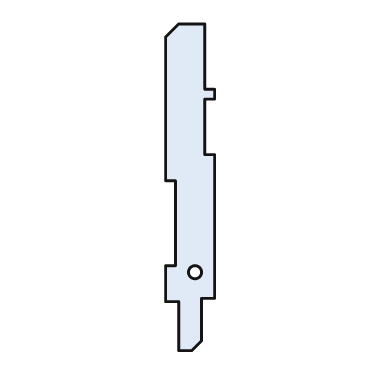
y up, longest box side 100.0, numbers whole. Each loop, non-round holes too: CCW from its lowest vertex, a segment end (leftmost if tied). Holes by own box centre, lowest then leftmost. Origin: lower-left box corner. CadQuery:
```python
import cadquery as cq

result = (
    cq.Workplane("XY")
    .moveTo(4.0, 0.0)
    .lineTo(8.0, 0.0)
    .lineTo(11.0, 3.0)
    .lineTo(11.0, 16.0)
    .lineTo(15.0, 16.0)
    .lineTo(15.0, 60.0)
    .lineTo(12.0, 60.0)
    .lineTo(12.0, 77.0)
    .lineTo(15.0, 77.0)
    .lineTo(15.0, 80.0)
    .lineTo(12.0, 80.0)
    .lineTo(12.0, 100.0)
    .lineTo(4.0, 100.0)
    .lineTo(0.0, 96.0)
    .lineTo(0.0, 52.0)
    .lineTo(3.0, 52.0)
    .lineTo(3.0, 26.0)
    .lineTo(0.0, 26.0)
    .lineTo(0.0, 15.0)
    .lineTo(4.0, 15.0)
    .close()
    .moveTo(9.0, 24.0)
    .circle(2.0)
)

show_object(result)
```